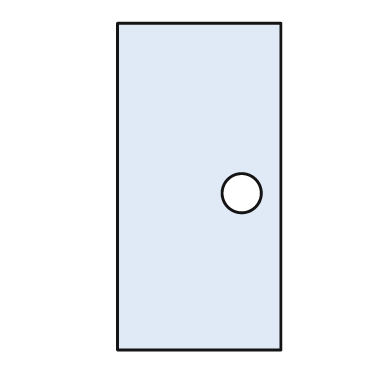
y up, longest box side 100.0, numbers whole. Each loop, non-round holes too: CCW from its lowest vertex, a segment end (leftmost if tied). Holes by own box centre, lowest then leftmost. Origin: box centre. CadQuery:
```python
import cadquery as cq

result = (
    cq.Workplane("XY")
    .moveTo(-25.0, -50.0)
    .lineTo(25.0, -50.0)
    .lineTo(25.0, 50.0)
    .lineTo(-25.0, 50.0)
    .close()
    .moveTo(13.0, -2.0)
    .circle(6.0)
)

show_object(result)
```